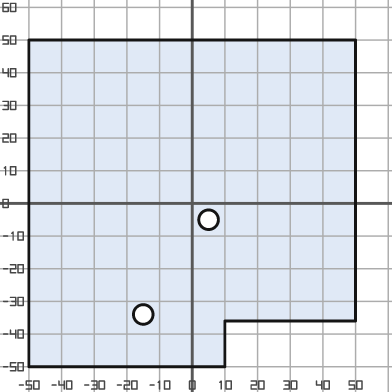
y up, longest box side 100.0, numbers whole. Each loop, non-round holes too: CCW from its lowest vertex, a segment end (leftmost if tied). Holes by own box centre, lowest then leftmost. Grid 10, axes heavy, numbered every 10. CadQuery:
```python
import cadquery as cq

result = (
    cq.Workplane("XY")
    .moveTo(-50.0, -50.0)
    .lineTo(10.0, -50.0)
    .lineTo(10.0, -36.0)
    .lineTo(50.0, -36.0)
    .lineTo(50.0, 50.0)
    .lineTo(-50.0, 50.0)
    .close()
    .moveTo(-15.0, -34.0)
    .circle(3.0)
    .moveTo(5.0, -5.0)
    .circle(3.0)
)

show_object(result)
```